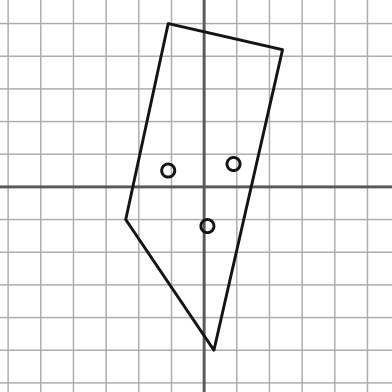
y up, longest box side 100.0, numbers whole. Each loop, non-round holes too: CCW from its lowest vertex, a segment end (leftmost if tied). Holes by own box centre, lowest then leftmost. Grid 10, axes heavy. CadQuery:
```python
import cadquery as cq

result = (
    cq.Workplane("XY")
    .moveTo(3.0, -50.0)
    .lineTo(24.0, 42.0)
    .lineTo(-11.0, 50.0)
    .lineTo(-24.0, -10.0)
    .close()
    .moveTo(1.0, -12.0)
    .circle(2.0)
    .moveTo(-11.0, 5.0)
    .circle(2.0)
    .moveTo(9.0, 7.0)
    .circle(2.0)
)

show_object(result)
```